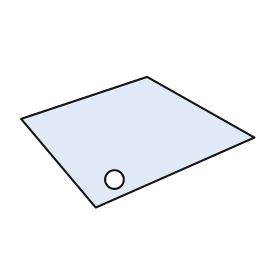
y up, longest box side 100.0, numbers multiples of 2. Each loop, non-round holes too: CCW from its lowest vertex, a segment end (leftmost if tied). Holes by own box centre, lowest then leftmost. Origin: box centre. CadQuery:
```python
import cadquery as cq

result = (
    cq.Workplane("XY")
    .moveTo(-18.0, -28.0)
    .lineTo(50.0, 2.0)
    .lineTo(4.0, 28.0)
    .lineTo(-50.0, 10.0)
    .close()
    .moveTo(-10.0, -16.0)
    .circle(4.0)
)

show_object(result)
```